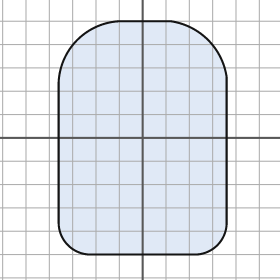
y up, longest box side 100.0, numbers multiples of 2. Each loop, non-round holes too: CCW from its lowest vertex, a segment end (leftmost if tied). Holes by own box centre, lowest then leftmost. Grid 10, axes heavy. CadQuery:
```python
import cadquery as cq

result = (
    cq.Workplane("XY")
    .moveTo(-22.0, -50.0)
    .lineTo(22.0, -50.0)
    .threePointArc((32.0, -46.0), (36.0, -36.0))
    .lineTo(36.0, 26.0)
    .threePointArc((28.0, 42.0), (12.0, 50.0))
    .lineTo(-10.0, 50.0)
    .threePointArc((-28.0, 42.0), (-36.0, 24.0))
    .lineTo(-36.0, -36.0)
    .threePointArc((-32.0, -46.0), (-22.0, -50.0))
    .close()
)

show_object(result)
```